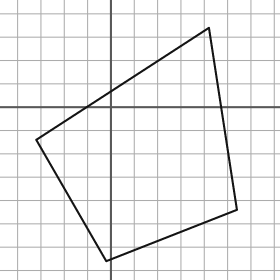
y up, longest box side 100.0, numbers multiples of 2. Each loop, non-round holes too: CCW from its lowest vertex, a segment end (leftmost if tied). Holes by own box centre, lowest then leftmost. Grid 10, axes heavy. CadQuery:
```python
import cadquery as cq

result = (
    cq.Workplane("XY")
    .moveTo(-2.0, -66.0)
    .lineTo(54.0, -44.0)
    .lineTo(42.0, 34.0)
    .lineTo(-32.0, -14.0)
    .close()
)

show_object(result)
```